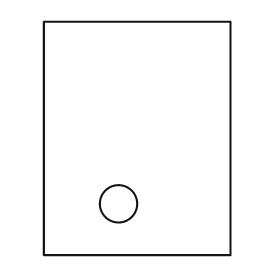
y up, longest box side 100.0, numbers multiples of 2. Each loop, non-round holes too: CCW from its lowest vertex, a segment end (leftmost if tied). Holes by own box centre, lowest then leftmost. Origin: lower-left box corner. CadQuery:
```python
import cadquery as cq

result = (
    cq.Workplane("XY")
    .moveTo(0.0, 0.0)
    .lineTo(80.0, 0.0)
    .lineTo(80.0, 100.0)
    .lineTo(0.0, 100.0)
    .close()
    .moveTo(32.0, 22.0)
    .circle(8.0)
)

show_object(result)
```